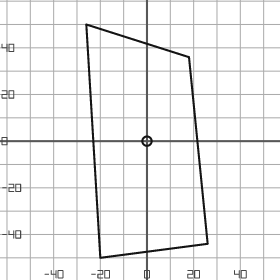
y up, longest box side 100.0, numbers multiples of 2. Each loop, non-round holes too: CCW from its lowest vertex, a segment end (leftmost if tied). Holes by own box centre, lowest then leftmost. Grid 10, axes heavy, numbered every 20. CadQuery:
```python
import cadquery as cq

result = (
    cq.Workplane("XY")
    .moveTo(-20.0, -50.0)
    .lineTo(26.0, -44.0)
    .lineTo(18.0, 36.0)
    .lineTo(-26.0, 50.0)
    .close()
    .moveTo(0.0, 0.0)
    .circle(2.0)
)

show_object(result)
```